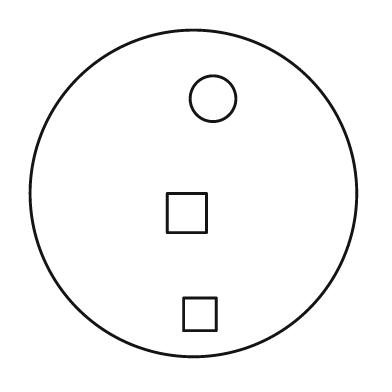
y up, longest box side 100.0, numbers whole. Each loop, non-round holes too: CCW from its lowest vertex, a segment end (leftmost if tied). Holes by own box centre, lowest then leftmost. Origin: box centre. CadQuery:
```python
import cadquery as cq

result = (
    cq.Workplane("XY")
    .moveTo(0.0, 0.0)
    .circle(50.0)
    .moveTo(-3.0, -42.0)
    .lineTo(7.0, -42.0)
    .lineTo(7.0, -32.0)
    .lineTo(-3.0, -32.0)
    .close()
    .moveTo(-8.0, -12.0)
    .lineTo(4.0, -12.0)
    .lineTo(4.0, 0.0)
    .lineTo(-8.0, 0.0)
    .close()
    .moveTo(6.0, 29.0)
    .circle(7.0)
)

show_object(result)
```